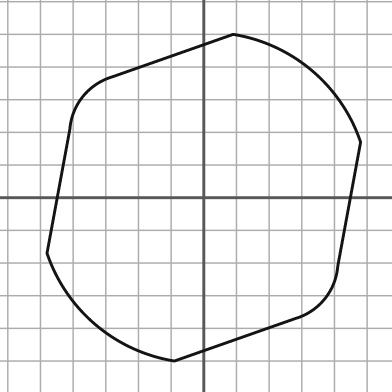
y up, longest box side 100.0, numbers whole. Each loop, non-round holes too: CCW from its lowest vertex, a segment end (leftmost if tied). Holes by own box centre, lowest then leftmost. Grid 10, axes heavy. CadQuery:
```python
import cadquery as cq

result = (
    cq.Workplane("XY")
    .moveTo(-9.0, -50.0)
    .lineTo(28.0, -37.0)
    .threePointArc((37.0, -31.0), (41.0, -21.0))
    .lineTo(48.0, 17.0)
    .threePointArc((33.0, 39.0), (9.0, 50.0))
    .lineTo(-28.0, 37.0)
    .threePointArc((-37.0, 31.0), (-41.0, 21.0))
    .lineTo(-48.0, -17.0)
    .threePointArc((-33.0, -39.0), (-9.0, -50.0))
    .close()
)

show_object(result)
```